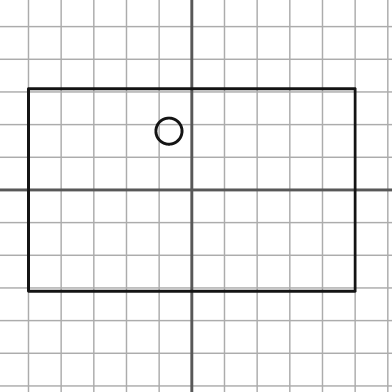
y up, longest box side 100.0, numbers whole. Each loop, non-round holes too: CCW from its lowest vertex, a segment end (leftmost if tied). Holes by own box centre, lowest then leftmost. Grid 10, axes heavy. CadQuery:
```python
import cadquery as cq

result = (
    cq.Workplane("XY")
    .moveTo(-50.0, -31.0)
    .lineTo(50.0, -31.0)
    .lineTo(50.0, 31.0)
    .lineTo(-50.0, 31.0)
    .close()
    .moveTo(-7.0, 18.0)
    .circle(4.0)
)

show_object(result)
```